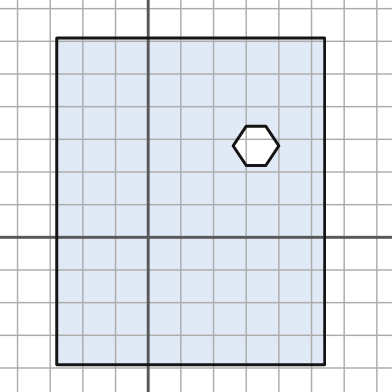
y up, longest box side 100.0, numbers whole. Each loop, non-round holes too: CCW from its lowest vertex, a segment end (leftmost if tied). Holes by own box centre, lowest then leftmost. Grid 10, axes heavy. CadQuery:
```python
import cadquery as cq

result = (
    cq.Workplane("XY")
    .moveTo(-28.0, -39.0)
    .lineTo(54.0, -39.0)
    .lineTo(54.0, 61.0)
    .lineTo(-28.0, 61.0)
    .close()
    .moveTo(30.0, 22.0)
    .lineTo(36.0, 22.0)
    .lineTo(40.0, 28.0)
    .lineTo(36.0, 34.0)
    .lineTo(30.0, 34.0)
    .lineTo(26.0, 28.0)
    .close()
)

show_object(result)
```